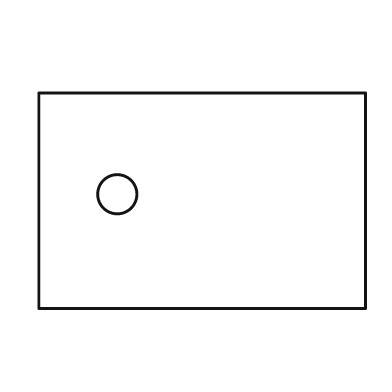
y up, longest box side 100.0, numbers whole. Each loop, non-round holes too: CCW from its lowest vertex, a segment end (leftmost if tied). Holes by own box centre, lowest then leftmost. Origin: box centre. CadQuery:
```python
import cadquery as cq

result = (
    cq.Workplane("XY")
    .moveTo(-50.0, -33.0)
    .lineTo(50.0, -33.0)
    .lineTo(50.0, 33.0)
    .lineTo(-50.0, 33.0)
    .close()
    .moveTo(-26.0, 2.0)
    .circle(6.0)
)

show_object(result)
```